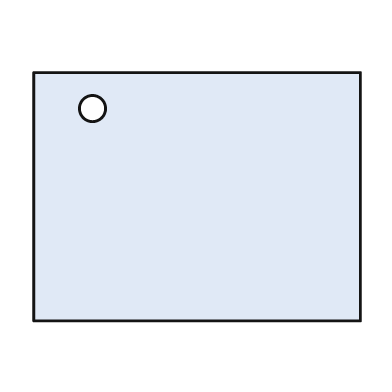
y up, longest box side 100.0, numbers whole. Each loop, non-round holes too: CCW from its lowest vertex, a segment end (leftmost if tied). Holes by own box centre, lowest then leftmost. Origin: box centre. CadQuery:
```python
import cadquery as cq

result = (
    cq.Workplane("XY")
    .moveTo(-50.0, -38.0)
    .lineTo(50.0, -38.0)
    .lineTo(50.0, 38.0)
    .lineTo(-50.0, 38.0)
    .close()
    .moveTo(-32.0, 27.0)
    .circle(4.0)
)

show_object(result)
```